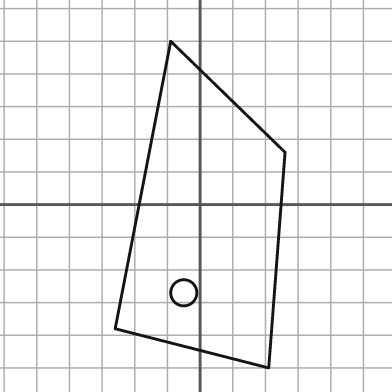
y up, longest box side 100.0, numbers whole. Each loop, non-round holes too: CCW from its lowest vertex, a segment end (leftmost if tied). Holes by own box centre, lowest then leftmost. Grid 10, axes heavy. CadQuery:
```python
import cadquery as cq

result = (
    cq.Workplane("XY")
    .moveTo(21.0, -50.0)
    .lineTo(26.0, 16.0)
    .lineTo(-9.0, 50.0)
    .lineTo(-26.0, -38.0)
    .close()
    .moveTo(-5.0, -27.0)
    .circle(4.0)
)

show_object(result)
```